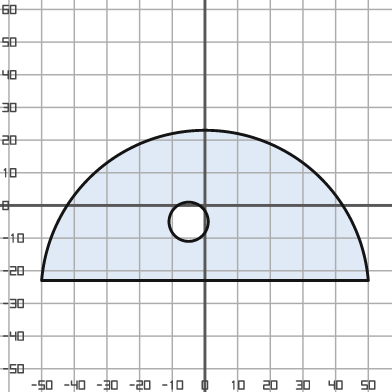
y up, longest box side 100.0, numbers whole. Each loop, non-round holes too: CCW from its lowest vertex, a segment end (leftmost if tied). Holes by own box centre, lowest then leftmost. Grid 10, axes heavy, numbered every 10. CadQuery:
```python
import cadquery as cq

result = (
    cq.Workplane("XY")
    .moveTo(-50.0, -23.0)
    .lineTo(50.0, -23.0)
    .threePointArc((0.0, 23.0), (-50.0, -23.0))
    .close()
    .moveTo(-5.0, -5.0)
    .circle(6.0)
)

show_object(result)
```